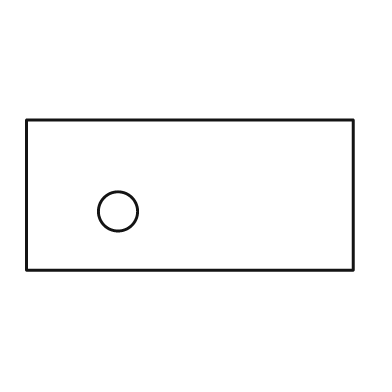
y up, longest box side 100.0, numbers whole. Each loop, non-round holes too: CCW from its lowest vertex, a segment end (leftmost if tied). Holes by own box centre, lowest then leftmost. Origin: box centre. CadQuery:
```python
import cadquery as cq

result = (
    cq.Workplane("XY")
    .moveTo(-50.0, -23.0)
    .lineTo(50.0, -23.0)
    .lineTo(50.0, 23.0)
    .lineTo(-50.0, 23.0)
    .close()
    .moveTo(-22.0, -5.0)
    .circle(6.0)
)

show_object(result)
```